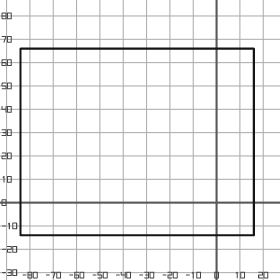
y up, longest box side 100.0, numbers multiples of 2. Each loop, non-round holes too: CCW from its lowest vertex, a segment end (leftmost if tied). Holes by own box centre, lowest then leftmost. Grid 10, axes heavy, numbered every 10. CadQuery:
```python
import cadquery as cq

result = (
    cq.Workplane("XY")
    .moveTo(-84.0, -14.0)
    .lineTo(16.0, -14.0)
    .lineTo(16.0, 66.0)
    .lineTo(-84.0, 66.0)
    .close()
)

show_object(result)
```